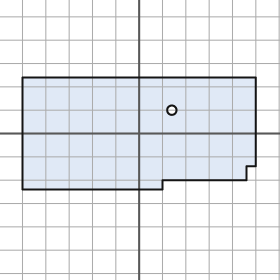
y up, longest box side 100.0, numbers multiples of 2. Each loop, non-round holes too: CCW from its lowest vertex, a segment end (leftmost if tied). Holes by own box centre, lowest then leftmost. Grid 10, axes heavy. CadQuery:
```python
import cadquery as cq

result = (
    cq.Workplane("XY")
    .moveTo(-50.0, -24.0)
    .lineTo(10.0, -24.0)
    .lineTo(10.0, -20.0)
    .lineTo(46.0, -20.0)
    .lineTo(46.0, -14.0)
    .lineTo(50.0, -14.0)
    .lineTo(50.0, 24.0)
    .lineTo(-50.0, 24.0)
    .close()
    .moveTo(14.0, 10.0)
    .circle(2.0)
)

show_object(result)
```